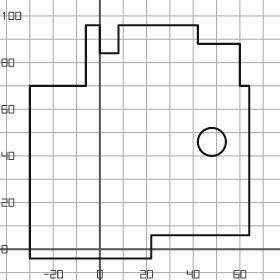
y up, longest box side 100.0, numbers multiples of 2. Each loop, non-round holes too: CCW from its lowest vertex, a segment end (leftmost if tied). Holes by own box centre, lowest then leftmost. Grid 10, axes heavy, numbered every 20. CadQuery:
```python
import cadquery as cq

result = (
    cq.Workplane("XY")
    .moveTo(-30.0, -4.0)
    .lineTo(22.0, -4.0)
    .lineTo(22.0, 6.0)
    .lineTo(64.0, 6.0)
    .lineTo(64.0, 70.0)
    .lineTo(60.0, 70.0)
    .lineTo(60.0, 88.0)
    .lineTo(42.0, 88.0)
    .lineTo(42.0, 96.0)
    .lineTo(8.0, 96.0)
    .lineTo(8.0, 84.0)
    .lineTo(0.0, 84.0)
    .lineTo(0.0, 96.0)
    .lineTo(-6.0, 96.0)
    .lineTo(-6.0, 70.0)
    .lineTo(-30.0, 70.0)
    .close()
    .moveTo(48.0, 46.0)
    .circle(6.0)
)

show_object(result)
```